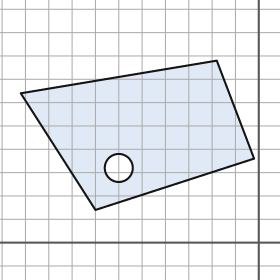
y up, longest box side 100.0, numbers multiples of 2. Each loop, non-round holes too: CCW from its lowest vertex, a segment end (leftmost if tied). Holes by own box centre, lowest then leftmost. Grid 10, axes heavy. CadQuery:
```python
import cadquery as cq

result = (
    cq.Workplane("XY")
    .moveTo(-70.0, 14.0)
    .lineTo(-2.0, 36.0)
    .lineTo(-18.0, 78.0)
    .lineTo(-102.0, 64.0)
    .close()
    .moveTo(-60.0, 32.0)
    .circle(6.0)
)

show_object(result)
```